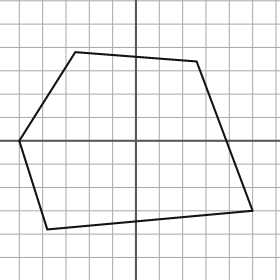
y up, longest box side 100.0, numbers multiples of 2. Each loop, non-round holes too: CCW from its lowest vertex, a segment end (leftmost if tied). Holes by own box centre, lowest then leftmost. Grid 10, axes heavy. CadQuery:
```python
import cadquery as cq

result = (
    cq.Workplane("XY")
    .moveTo(-38.0, -38.0)
    .lineTo(50.0, -30.0)
    .lineTo(26.0, 34.0)
    .lineTo(-26.0, 38.0)
    .lineTo(-50.0, 0.0)
    .close()
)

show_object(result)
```